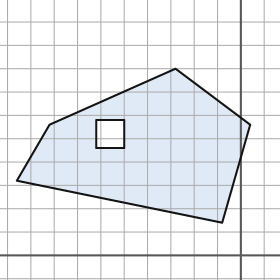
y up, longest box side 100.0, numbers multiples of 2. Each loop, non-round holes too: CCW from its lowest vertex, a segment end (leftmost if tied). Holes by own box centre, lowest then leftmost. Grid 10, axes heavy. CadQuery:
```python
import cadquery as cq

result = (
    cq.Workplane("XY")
    .moveTo(-8.0, 14.0)
    .lineTo(4.0, 56.0)
    .lineTo(-28.0, 80.0)
    .lineTo(-82.0, 56.0)
    .lineTo(-96.0, 32.0)
    .close()
    .moveTo(-62.0, 46.0)
    .lineTo(-50.0, 46.0)
    .lineTo(-50.0, 58.0)
    .lineTo(-62.0, 58.0)
    .close()
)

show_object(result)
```